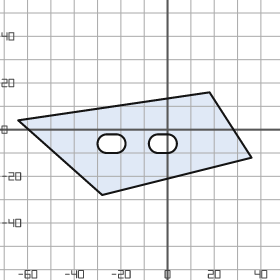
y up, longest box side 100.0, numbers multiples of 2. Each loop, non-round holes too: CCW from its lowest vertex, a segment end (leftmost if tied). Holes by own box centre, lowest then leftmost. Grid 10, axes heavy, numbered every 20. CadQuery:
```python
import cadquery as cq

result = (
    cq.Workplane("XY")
    .moveTo(-28.0, -28.0)
    .lineTo(36.0, -12.0)
    .lineTo(18.0, 16.0)
    .lineTo(-64.0, 4.0)
    .close()
    .moveTo(-26.0, -10.0)
    .lineTo(-22.0, -10.0)
    .threePointArc((-18.0, -6.0), (-22.0, -2.0))
    .lineTo(-26.0, -2.0)
    .threePointArc((-30.0, -6.0), (-26.0, -10.0))
    .close()
    .moveTo(-4.0, -10.0)
    .lineTo(0.0, -10.0)
    .threePointArc((4.0, -6.0), (0.0, -2.0))
    .lineTo(-4.0, -2.0)
    .threePointArc((-8.0, -6.0), (-4.0, -10.0))
    .close()
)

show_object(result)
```